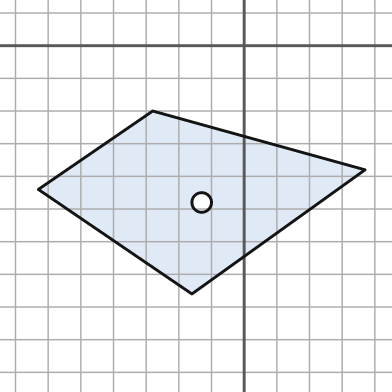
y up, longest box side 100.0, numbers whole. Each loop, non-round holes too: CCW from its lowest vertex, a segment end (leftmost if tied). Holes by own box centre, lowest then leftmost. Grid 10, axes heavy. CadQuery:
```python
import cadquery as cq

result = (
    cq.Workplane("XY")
    .moveTo(-16.0, -76.0)
    .lineTo(37.0, -38.0)
    .lineTo(-28.0, -20.0)
    .lineTo(-63.0, -44.0)
    .close()
    .moveTo(-13.0, -48.0)
    .circle(3.0)
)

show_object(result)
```